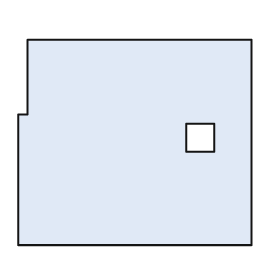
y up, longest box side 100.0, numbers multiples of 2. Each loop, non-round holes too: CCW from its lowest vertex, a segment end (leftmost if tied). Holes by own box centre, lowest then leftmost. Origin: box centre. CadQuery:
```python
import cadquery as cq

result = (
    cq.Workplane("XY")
    .moveTo(-50.0, -44.0)
    .lineTo(50.0, -44.0)
    .lineTo(50.0, 44.0)
    .lineTo(-46.0, 44.0)
    .lineTo(-46.0, 12.0)
    .lineTo(-50.0, 12.0)
    .close()
    .moveTo(22.0, -4.0)
    .lineTo(34.0, -4.0)
    .lineTo(34.0, 8.0)
    .lineTo(22.0, 8.0)
    .close()
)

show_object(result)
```